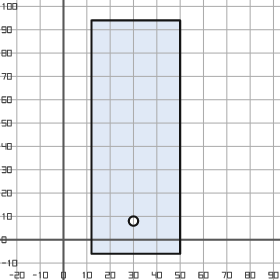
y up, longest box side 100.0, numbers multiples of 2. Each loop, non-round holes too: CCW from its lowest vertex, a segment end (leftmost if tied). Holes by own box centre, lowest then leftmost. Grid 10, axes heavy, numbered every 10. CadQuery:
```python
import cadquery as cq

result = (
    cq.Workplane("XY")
    .moveTo(12.0, -6.0)
    .lineTo(50.0, -6.0)
    .lineTo(50.0, 94.0)
    .lineTo(12.0, 94.0)
    .close()
    .moveTo(30.0, 8.0)
    .circle(2.0)
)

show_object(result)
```